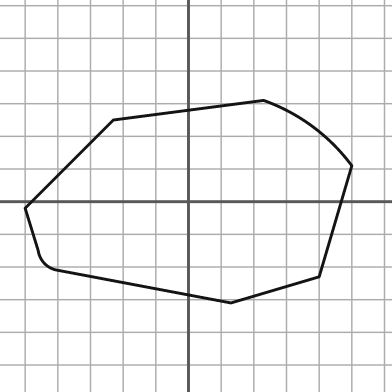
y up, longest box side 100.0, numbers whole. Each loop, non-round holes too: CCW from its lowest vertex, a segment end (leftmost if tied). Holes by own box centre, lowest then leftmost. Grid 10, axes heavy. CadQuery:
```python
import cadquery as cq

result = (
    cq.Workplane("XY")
    .moveTo(13.0, -31.0)
    .lineTo(40.0, -23.0)
    .lineTo(50.0, 11.0)
    .threePointArc((38.0, 23.0), (23.0, 31.0))
    .lineTo(-23.0, 25.0)
    .lineTo(-50.0, -2.0)
    .lineTo(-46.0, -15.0)
    .threePointArc((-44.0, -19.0), (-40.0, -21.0))
    .close()
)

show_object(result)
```